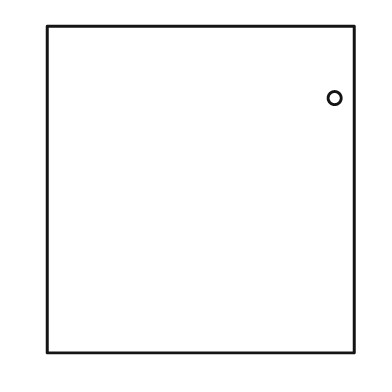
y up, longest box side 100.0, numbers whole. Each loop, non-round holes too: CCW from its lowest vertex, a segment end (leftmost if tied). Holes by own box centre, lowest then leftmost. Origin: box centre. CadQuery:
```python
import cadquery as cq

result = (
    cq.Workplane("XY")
    .moveTo(-47.0, -50.0)
    .lineTo(47.0, -50.0)
    .lineTo(47.0, 50.0)
    .lineTo(-47.0, 50.0)
    .close()
    .moveTo(41.0, 28.0)
    .circle(2.0)
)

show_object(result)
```